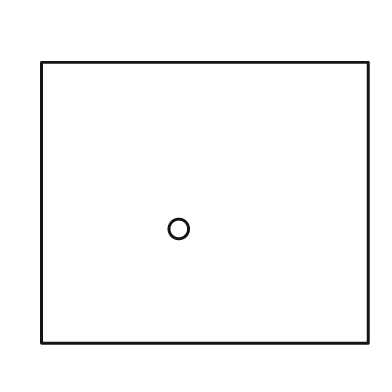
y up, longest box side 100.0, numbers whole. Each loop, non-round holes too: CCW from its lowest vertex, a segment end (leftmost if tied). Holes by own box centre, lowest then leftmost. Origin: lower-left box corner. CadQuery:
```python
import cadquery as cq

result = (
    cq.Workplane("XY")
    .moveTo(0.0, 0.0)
    .lineTo(100.0, 0.0)
    .lineTo(100.0, 86.0)
    .lineTo(0.0, 86.0)
    .close()
    .moveTo(42.0, 35.0)
    .circle(3.0)
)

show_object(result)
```